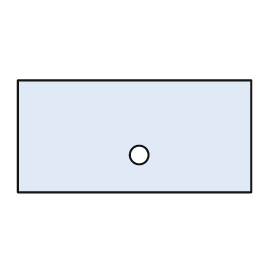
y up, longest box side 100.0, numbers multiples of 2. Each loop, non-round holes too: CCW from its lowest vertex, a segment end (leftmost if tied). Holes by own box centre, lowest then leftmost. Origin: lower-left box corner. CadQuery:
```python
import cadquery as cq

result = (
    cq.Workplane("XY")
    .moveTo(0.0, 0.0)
    .lineTo(100.0, 0.0)
    .lineTo(100.0, 48.0)
    .lineTo(0.0, 48.0)
    .close()
    .moveTo(52.0, 16.0)
    .circle(4.0)
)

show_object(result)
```